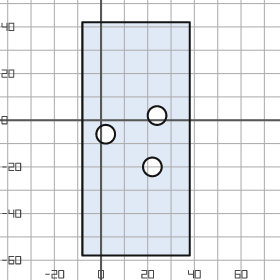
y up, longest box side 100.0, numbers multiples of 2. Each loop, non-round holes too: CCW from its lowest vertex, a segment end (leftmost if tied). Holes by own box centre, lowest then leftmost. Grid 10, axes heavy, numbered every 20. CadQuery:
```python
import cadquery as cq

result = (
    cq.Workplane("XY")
    .moveTo(-8.0, -58.0)
    .lineTo(38.0, -58.0)
    .lineTo(38.0, 42.0)
    .lineTo(-8.0, 42.0)
    .close()
    .moveTo(22.0, -20.0)
    .circle(4.0)
    .moveTo(2.0, -6.0)
    .circle(4.0)
    .moveTo(24.0, 2.0)
    .circle(4.0)
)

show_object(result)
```